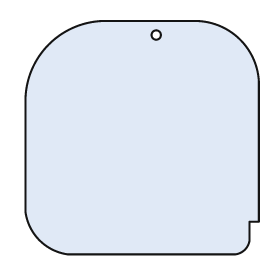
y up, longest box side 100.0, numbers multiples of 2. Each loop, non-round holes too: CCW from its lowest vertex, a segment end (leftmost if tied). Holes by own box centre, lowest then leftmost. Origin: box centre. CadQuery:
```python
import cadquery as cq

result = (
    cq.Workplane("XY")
    .moveTo(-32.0, -50.0)
    .lineTo(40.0, -50.0)
    .threePointArc((44.0, -48.0), (46.0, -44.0))
    .lineTo(46.0, -36.0)
    .lineTo(50.0, -36.0)
    .lineTo(50.0, 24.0)
    .threePointArc((42.0, 42.0), (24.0, 50.0))
    .lineTo(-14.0, 50.0)
    .threePointArc((-40.0, 40.0), (-50.0, 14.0))
    .lineTo(-50.0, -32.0)
    .threePointArc((-44.0, -44.0), (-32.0, -50.0))
    .close()
    .moveTo(6.0, 44.0)
    .circle(2.0)
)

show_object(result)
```